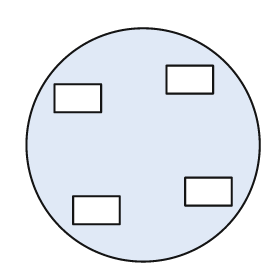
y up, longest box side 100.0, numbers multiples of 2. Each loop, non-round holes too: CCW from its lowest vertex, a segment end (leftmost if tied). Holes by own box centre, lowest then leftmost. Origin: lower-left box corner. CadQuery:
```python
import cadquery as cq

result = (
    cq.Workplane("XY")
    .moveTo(50.0, 50.0)
    .circle(50.0)
    .moveTo(20.0, 16.0)
    .lineTo(40.0, 16.0)
    .lineTo(40.0, 28.0)
    .lineTo(20.0, 28.0)
    .close()
    .moveTo(68.0, 24.0)
    .lineTo(88.0, 24.0)
    .lineTo(88.0, 36.0)
    .lineTo(68.0, 36.0)
    .close()
    .moveTo(12.0, 64.0)
    .lineTo(32.0, 64.0)
    .lineTo(32.0, 76.0)
    .lineTo(12.0, 76.0)
    .close()
    .moveTo(60.0, 72.0)
    .lineTo(80.0, 72.0)
    .lineTo(80.0, 84.0)
    .lineTo(60.0, 84.0)
    .close()
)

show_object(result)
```